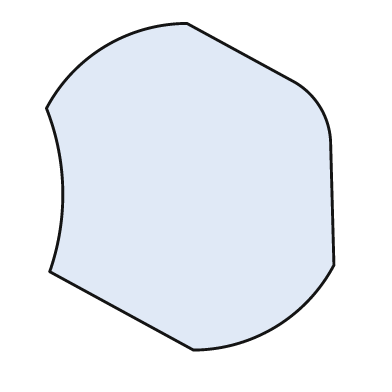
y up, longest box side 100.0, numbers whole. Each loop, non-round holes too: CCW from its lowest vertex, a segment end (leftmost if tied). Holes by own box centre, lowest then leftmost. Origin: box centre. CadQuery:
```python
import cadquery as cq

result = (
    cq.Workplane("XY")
    .moveTo(1.0, -50.0)
    .threePointArc((26.0, -43.0), (44.0, -24.0))
    .lineTo(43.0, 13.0)
    .threePointArc((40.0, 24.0), (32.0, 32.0))
    .lineTo(-1.0, 50.0)
    .threePointArc((-26.0, 43.0), (-44.0, 24.0))
    .threePointArc((-39.0, -1.0), (-43.0, -26.0))
    .close()
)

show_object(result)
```